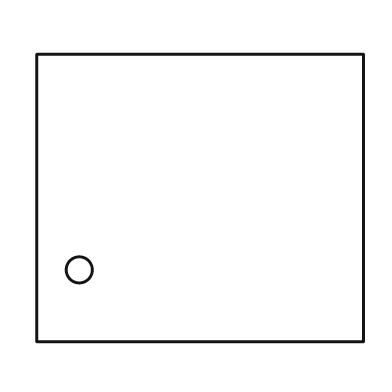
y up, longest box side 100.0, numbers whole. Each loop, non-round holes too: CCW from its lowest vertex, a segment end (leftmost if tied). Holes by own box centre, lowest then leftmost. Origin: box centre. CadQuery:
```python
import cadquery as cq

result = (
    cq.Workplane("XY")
    .moveTo(-50.0, -44.0)
    .lineTo(50.0, -44.0)
    .lineTo(50.0, 44.0)
    .lineTo(-50.0, 44.0)
    .close()
    .moveTo(-37.0, -22.0)
    .circle(4.0)
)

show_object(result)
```